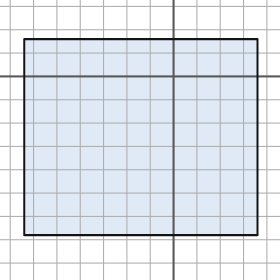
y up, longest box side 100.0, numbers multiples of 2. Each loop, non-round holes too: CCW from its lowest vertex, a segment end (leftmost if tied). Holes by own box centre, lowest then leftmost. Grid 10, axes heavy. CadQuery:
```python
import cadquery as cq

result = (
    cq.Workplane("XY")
    .moveTo(-64.0, -68.0)
    .lineTo(36.0, -68.0)
    .lineTo(36.0, 16.0)
    .lineTo(-64.0, 16.0)
    .close()
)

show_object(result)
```